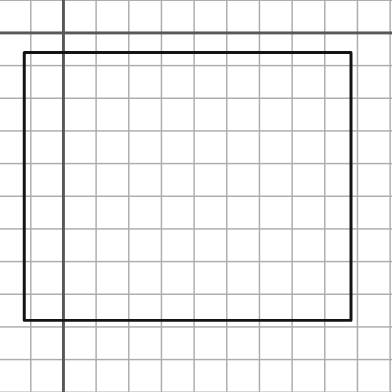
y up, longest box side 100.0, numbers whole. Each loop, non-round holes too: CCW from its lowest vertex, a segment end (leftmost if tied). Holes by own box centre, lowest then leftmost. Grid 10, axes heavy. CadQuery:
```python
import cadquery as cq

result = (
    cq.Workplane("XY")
    .moveTo(-12.0, -88.0)
    .lineTo(88.0, -88.0)
    .lineTo(88.0, -6.0)
    .lineTo(-12.0, -6.0)
    .close()
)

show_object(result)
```